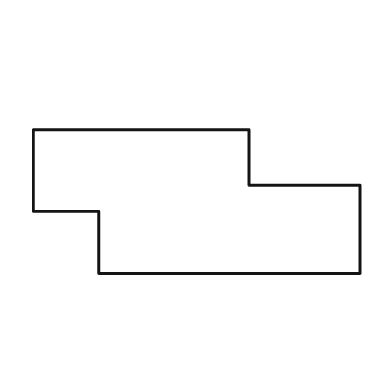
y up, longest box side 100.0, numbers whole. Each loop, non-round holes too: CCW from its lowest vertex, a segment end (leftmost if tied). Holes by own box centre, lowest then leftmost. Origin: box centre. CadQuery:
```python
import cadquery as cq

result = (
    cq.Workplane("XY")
    .moveTo(-30.0, -22.0)
    .lineTo(50.0, -22.0)
    .lineTo(50.0, 5.0)
    .lineTo(16.0, 5.0)
    .lineTo(16.0, 22.0)
    .lineTo(-50.0, 22.0)
    .lineTo(-50.0, -3.0)
    .lineTo(-30.0, -3.0)
    .close()
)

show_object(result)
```